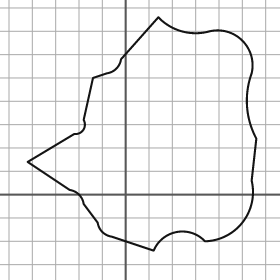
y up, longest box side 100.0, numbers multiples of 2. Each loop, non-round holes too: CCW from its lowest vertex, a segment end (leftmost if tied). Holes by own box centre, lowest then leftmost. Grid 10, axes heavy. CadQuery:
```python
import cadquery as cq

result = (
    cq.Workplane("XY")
    .moveTo(12.0, -24.0)
    .threePointArc((22.0, -16.0), (34.0, -20.0))
    .threePointArc((50.0, -12.0), (54.0, 6.0))
    .lineTo(56.0, 24.0)
    .threePointArc((52.0, 38.0), (54.0, 52.0))
    .threePointArc((50.0, 66.0), (36.0, 70.0))
    .threePointArc((24.0, 70.0), (14.0, 76.0))
    .lineTo(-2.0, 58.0)
    .threePointArc((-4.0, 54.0), (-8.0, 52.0))
    .lineTo(-14.0, 50.0)
    .lineTo(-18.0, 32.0)
    .threePointArc((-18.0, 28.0), (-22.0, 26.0))
    .lineTo(-42.0, 14.0)
    .lineTo(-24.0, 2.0)
    .threePointArc((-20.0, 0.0), (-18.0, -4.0))
    .lineTo(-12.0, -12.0)
    .threePointArc((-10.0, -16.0), (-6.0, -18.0))
    .close()
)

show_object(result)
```